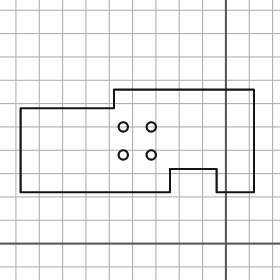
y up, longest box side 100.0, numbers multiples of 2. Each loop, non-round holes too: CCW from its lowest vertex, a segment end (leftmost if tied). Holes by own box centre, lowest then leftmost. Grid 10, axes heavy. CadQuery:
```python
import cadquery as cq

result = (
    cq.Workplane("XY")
    .moveTo(-88.0, 22.0)
    .lineTo(-24.0, 22.0)
    .lineTo(-24.0, 32.0)
    .lineTo(-4.0, 32.0)
    .lineTo(-4.0, 22.0)
    .lineTo(12.0, 22.0)
    .lineTo(12.0, 66.0)
    .lineTo(-48.0, 66.0)
    .lineTo(-48.0, 58.0)
    .lineTo(-88.0, 58.0)
    .close()
    .moveTo(-44.0, 38.0)
    .circle(2.0)
    .moveTo(-32.0, 38.0)
    .circle(2.0)
    .moveTo(-44.0, 50.0)
    .circle(2.0)
    .moveTo(-32.0, 50.0)
    .circle(2.0)
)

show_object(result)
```